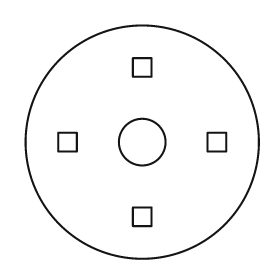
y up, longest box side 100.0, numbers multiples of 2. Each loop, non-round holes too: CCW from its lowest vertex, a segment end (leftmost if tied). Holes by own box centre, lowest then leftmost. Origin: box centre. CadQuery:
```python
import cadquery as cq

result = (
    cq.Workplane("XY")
    .moveTo(0.0, 0.0)
    .circle(50.0)
    .moveTo(-4.0, -36.0)
    .lineTo(4.0, -36.0)
    .lineTo(4.0, -28.0)
    .lineTo(-4.0, -28.0)
    .close()
    .moveTo(-36.0, -4.0)
    .lineTo(-28.0, -4.0)
    .lineTo(-28.0, 4.0)
    .lineTo(-36.0, 4.0)
    .close()
    .moveTo(0.0, 0.0)
    .circle(10.0)
    .moveTo(28.0, -4.0)
    .lineTo(36.0, -4.0)
    .lineTo(36.0, 4.0)
    .lineTo(28.0, 4.0)
    .close()
    .moveTo(-4.0, 28.0)
    .lineTo(4.0, 28.0)
    .lineTo(4.0, 36.0)
    .lineTo(-4.0, 36.0)
    .close()
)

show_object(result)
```